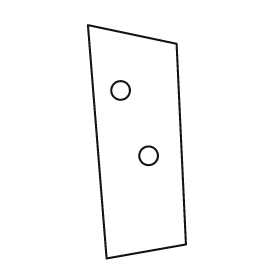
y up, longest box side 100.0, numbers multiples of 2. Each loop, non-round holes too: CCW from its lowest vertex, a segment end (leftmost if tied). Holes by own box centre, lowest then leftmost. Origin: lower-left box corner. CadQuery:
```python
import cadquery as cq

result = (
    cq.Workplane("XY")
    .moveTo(8.0, 0.0)
    .lineTo(42.0, 6.0)
    .lineTo(38.0, 92.0)
    .lineTo(0.0, 100.0)
    .close()
    .moveTo(26.0, 44.0)
    .circle(4.0)
    .moveTo(14.0, 72.0)
    .circle(4.0)
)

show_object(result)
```